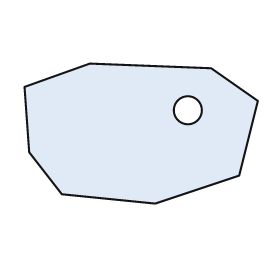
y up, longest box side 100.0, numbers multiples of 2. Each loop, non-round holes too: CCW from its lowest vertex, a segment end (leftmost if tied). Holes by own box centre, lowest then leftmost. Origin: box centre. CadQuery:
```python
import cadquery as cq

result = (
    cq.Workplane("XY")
    .moveTo(6.0, -30.0)
    .lineTo(42.0, -18.0)
    .lineTo(50.0, 14.0)
    .lineTo(30.0, 28.0)
    .lineTo(-22.0, 30.0)
    .lineTo(-50.0, 20.0)
    .lineTo(-48.0, -8.0)
    .lineTo(-34.0, -26.0)
    .close()
    .moveTo(20.0, 10.0)
    .circle(6.0)
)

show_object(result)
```